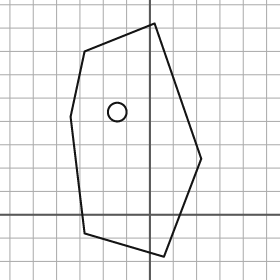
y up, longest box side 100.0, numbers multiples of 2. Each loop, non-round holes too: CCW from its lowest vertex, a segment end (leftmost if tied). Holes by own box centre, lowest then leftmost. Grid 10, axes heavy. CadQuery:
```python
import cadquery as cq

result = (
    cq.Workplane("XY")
    .moveTo(6.0, -18.0)
    .lineTo(22.0, 24.0)
    .lineTo(2.0, 82.0)
    .lineTo(-28.0, 70.0)
    .lineTo(-34.0, 42.0)
    .lineTo(-28.0, -8.0)
    .close()
    .moveTo(-14.0, 44.0)
    .circle(4.0)
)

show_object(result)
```